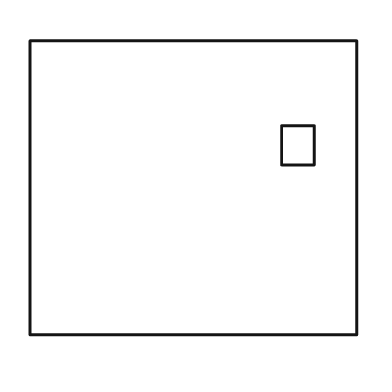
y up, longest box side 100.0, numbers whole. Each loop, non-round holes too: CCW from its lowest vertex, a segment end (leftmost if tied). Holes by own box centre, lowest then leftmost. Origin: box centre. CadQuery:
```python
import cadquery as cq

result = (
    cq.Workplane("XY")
    .moveTo(-50.0, -45.0)
    .lineTo(50.0, -45.0)
    .lineTo(50.0, 45.0)
    .lineTo(-50.0, 45.0)
    .close()
    .moveTo(27.0, 7.0)
    .lineTo(37.0, 7.0)
    .lineTo(37.0, 19.0)
    .lineTo(27.0, 19.0)
    .close()
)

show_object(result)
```